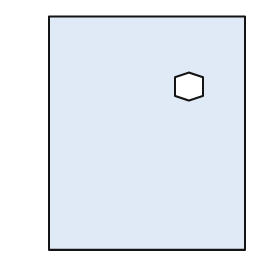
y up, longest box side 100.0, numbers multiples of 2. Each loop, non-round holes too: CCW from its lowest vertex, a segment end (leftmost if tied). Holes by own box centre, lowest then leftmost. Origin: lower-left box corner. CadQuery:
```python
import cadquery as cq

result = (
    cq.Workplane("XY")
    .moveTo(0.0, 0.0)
    .lineTo(84.0, 0.0)
    .lineTo(84.0, 100.0)
    .lineTo(0.0, 100.0)
    .close()
    .moveTo(60.0, 64.0)
    .lineTo(66.0, 66.0)
    .lineTo(66.0, 74.0)
    .lineTo(60.0, 76.0)
    .lineTo(54.0, 74.0)
    .lineTo(54.0, 66.0)
    .close()
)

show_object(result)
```